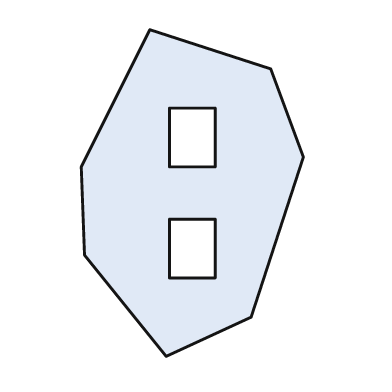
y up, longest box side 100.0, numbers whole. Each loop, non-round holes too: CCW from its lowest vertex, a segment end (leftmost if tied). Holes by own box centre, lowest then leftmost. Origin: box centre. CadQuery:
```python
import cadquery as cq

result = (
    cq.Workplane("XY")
    .moveTo(-8.0, -50.0)
    .lineTo(18.0, -38.0)
    .lineTo(34.0, 11.0)
    .lineTo(24.0, 38.0)
    .lineTo(-13.0, 50.0)
    .lineTo(-34.0, 8.0)
    .lineTo(-33.0, -19.0)
    .close()
    .moveTo(-7.0, -26.0)
    .lineTo(7.0, -26.0)
    .lineTo(7.0, -8.0)
    .lineTo(-7.0, -8.0)
    .close()
    .moveTo(-7.0, 8.0)
    .lineTo(7.0, 8.0)
    .lineTo(7.0, 26.0)
    .lineTo(-7.0, 26.0)
    .close()
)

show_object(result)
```